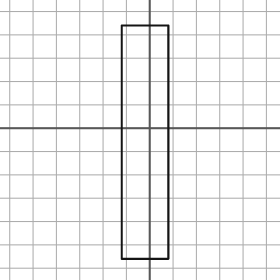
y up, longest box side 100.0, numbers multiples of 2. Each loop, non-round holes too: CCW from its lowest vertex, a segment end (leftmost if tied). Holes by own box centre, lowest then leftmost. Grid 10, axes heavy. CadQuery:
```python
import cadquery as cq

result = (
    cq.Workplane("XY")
    .moveTo(-12.0, -56.0)
    .lineTo(8.0, -56.0)
    .lineTo(8.0, 44.0)
    .lineTo(-12.0, 44.0)
    .close()
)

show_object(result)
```